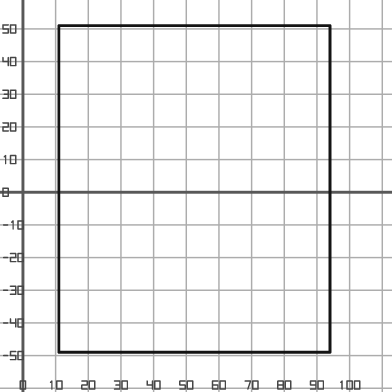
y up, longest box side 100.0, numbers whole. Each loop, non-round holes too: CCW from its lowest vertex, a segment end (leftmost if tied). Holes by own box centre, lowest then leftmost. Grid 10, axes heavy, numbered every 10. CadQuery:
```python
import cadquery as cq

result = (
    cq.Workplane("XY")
    .moveTo(11.0, -49.0)
    .lineTo(94.0, -49.0)
    .lineTo(94.0, 51.0)
    .lineTo(11.0, 51.0)
    .close()
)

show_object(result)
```